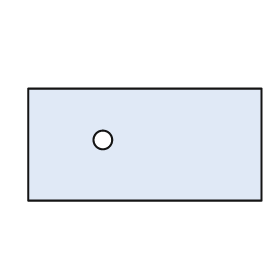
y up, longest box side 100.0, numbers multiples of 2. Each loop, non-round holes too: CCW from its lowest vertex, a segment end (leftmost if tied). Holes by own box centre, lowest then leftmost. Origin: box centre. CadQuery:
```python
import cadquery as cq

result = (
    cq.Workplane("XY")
    .moveTo(-50.0, -24.0)
    .lineTo(50.0, -24.0)
    .lineTo(50.0, 24.0)
    .lineTo(-50.0, 24.0)
    .close()
    .moveTo(-18.0, 2.0)
    .circle(4.0)
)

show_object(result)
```